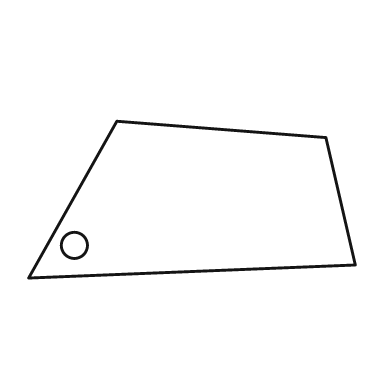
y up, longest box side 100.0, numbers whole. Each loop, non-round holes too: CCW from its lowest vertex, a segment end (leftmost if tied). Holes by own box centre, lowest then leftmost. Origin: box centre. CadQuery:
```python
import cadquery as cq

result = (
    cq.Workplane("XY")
    .moveTo(-50.0, -24.0)
    .lineTo(50.0, -20.0)
    .lineTo(41.0, 19.0)
    .lineTo(-23.0, 24.0)
    .close()
    .moveTo(-36.0, -14.0)
    .circle(4.0)
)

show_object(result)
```